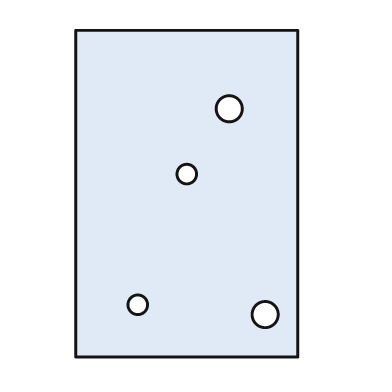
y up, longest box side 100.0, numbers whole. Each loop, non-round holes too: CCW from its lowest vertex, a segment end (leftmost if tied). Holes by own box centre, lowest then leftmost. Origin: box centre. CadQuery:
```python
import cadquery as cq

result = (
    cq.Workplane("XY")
    .moveTo(-34.0, -50.0)
    .lineTo(34.0, -50.0)
    .lineTo(34.0, 50.0)
    .lineTo(-34.0, 50.0)
    .close()
    .moveTo(24.0, -37.0)
    .circle(4.0)
    .moveTo(-15.0, -34.0)
    .circle(3.0)
    .moveTo(0.0, 6.0)
    .circle(3.0)
    .moveTo(13.0, 26.0)
    .circle(4.0)
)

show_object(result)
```